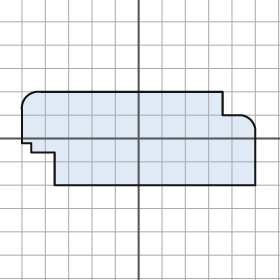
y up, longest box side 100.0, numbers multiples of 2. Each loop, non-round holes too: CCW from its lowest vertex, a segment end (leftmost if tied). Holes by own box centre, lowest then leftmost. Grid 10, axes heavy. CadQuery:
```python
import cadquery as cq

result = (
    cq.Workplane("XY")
    .moveTo(-36.0, -20.0)
    .lineTo(50.0, -20.0)
    .lineTo(50.0, 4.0)
    .threePointArc((48.0, 8.0), (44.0, 10.0))
    .lineTo(36.0, 10.0)
    .lineTo(36.0, 20.0)
    .lineTo(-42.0, 20.0)
    .threePointArc((-48.0, 18.0), (-50.0, 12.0))
    .lineTo(-50.0, -2.0)
    .lineTo(-46.0, -2.0)
    .lineTo(-46.0, -6.0)
    .lineTo(-36.0, -6.0)
    .close()
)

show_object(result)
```